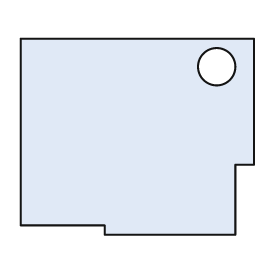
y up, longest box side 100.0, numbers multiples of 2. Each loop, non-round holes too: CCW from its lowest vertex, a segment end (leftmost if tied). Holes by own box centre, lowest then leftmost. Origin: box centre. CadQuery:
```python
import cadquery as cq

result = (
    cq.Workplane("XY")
    .moveTo(-14.0, -42.0)
    .lineTo(42.0, -42.0)
    .lineTo(42.0, -12.0)
    .lineTo(50.0, -12.0)
    .lineTo(50.0, 42.0)
    .lineTo(-50.0, 42.0)
    .lineTo(-50.0, -38.0)
    .lineTo(-14.0, -38.0)
    .close()
    .moveTo(34.0, 30.0)
    .circle(8.0)
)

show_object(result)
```